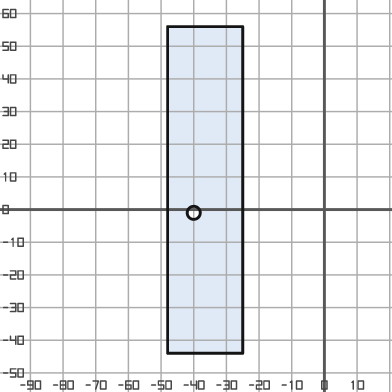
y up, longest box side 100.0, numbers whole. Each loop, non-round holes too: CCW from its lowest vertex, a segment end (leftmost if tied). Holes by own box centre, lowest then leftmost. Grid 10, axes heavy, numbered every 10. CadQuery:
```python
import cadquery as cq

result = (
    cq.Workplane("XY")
    .moveTo(-48.0, -44.0)
    .lineTo(-25.0, -44.0)
    .lineTo(-25.0, 56.0)
    .lineTo(-48.0, 56.0)
    .close()
    .moveTo(-40.0, -1.0)
    .circle(2.0)
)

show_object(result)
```